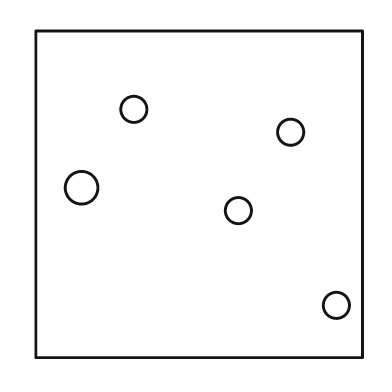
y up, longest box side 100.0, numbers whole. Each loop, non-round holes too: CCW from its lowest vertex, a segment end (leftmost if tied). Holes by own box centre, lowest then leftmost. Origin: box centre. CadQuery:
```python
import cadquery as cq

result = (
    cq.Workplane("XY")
    .moveTo(-50.0, -50.0)
    .lineTo(50.0, -50.0)
    .lineTo(50.0, 50.0)
    .lineTo(-50.0, 50.0)
    .close()
    .moveTo(42.0, -34.0)
    .circle(4.0)
    .moveTo(12.0, -5.0)
    .circle(4.0)
    .moveTo(-36.0, 2.0)
    .circle(5.0)
    .moveTo(28.0, 19.0)
    .circle(4.0)
    .moveTo(-20.0, 26.0)
    .circle(4.0)
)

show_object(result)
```